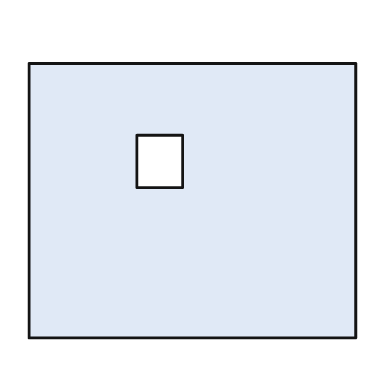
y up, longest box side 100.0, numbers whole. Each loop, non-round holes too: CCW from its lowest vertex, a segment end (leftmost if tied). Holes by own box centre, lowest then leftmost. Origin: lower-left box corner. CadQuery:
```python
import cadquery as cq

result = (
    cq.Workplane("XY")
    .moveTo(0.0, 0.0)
    .lineTo(100.0, 0.0)
    .lineTo(100.0, 84.0)
    .lineTo(0.0, 84.0)
    .close()
    .moveTo(33.0, 46.0)
    .lineTo(47.0, 46.0)
    .lineTo(47.0, 62.0)
    .lineTo(33.0, 62.0)
    .close()
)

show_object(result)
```